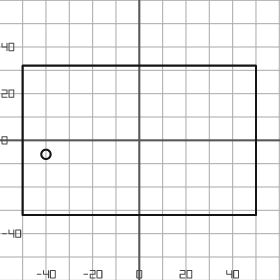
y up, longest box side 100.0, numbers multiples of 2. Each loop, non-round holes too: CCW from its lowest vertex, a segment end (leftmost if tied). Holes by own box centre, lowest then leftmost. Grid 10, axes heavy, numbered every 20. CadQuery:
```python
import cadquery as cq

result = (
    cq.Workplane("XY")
    .moveTo(-50.0, -32.0)
    .lineTo(50.0, -32.0)
    .lineTo(50.0, 32.0)
    .lineTo(-50.0, 32.0)
    .close()
    .moveTo(-40.0, -6.0)
    .circle(2.0)
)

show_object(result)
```